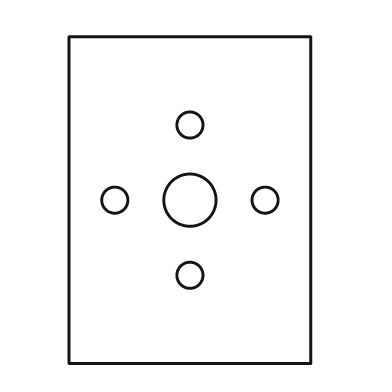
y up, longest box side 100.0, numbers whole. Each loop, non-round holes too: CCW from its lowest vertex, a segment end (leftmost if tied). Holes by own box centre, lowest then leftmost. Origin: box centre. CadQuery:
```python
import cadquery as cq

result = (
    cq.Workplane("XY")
    .moveTo(-37.0, -50.0)
    .lineTo(37.0, -50.0)
    .lineTo(37.0, 50.0)
    .lineTo(-37.0, 50.0)
    .close()
    .moveTo(0.0, -23.0)
    .circle(4.0)
    .moveTo(-23.0, 0.0)
    .circle(4.0)
    .moveTo(0.0, 0.0)
    .circle(8.0)
    .moveTo(23.0, 0.0)
    .circle(4.0)
    .moveTo(0.0, 23.0)
    .circle(4.0)
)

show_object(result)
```